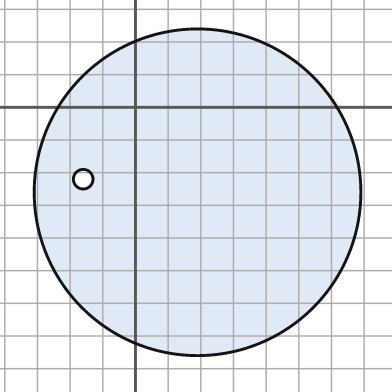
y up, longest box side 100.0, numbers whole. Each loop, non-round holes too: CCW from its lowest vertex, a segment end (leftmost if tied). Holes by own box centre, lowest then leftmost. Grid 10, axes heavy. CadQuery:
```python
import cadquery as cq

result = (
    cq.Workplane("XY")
    .moveTo(19.0, -26.0)
    .circle(50.0)
    .moveTo(-16.0, -22.0)
    .circle(3.0)
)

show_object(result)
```